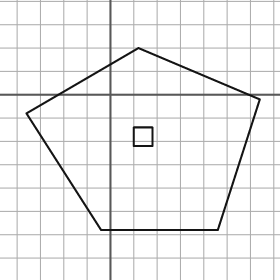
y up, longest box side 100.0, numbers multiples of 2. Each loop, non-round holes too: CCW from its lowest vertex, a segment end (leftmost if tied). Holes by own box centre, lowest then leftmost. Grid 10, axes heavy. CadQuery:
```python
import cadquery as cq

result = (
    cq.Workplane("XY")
    .moveTo(-4.0, -58.0)
    .lineTo(46.0, -58.0)
    .lineTo(64.0, -2.0)
    .lineTo(12.0, 20.0)
    .lineTo(-36.0, -8.0)
    .close()
    .moveTo(10.0, -22.0)
    .lineTo(18.0, -22.0)
    .lineTo(18.0, -14.0)
    .lineTo(10.0, -14.0)
    .close()
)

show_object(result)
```